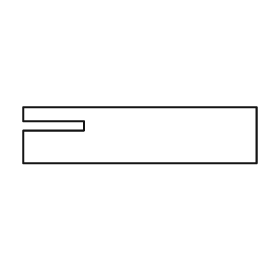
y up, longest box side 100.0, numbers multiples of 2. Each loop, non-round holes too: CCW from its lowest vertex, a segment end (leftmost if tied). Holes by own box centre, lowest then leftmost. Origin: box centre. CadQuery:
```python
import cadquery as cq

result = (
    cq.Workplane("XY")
    .moveTo(-50.0, -12.0)
    .lineTo(50.0, -12.0)
    .lineTo(50.0, 12.0)
    .lineTo(-50.0, 12.0)
    .lineTo(-50.0, 6.0)
    .lineTo(-24.0, 6.0)
    .lineTo(-24.0, 2.0)
    .lineTo(-50.0, 2.0)
    .close()
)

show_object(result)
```